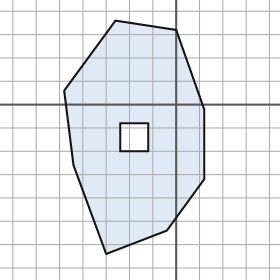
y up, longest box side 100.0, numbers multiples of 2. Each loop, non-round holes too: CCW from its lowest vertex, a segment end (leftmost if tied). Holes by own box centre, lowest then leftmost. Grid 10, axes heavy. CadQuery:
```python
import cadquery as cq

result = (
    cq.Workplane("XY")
    .moveTo(-30.0, -64.0)
    .lineTo(-4.0, -54.0)
    .lineTo(12.0, -32.0)
    .lineTo(12.0, -2.0)
    .lineTo(0.0, 32.0)
    .lineTo(-26.0, 36.0)
    .lineTo(-48.0, 6.0)
    .lineTo(-44.0, -26.0)
    .close()
    .moveTo(-24.0, -20.0)
    .lineTo(-12.0, -20.0)
    .lineTo(-12.0, -8.0)
    .lineTo(-24.0, -8.0)
    .close()
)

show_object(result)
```